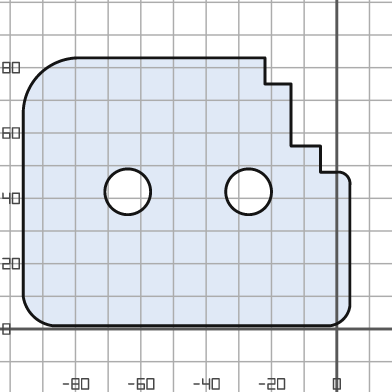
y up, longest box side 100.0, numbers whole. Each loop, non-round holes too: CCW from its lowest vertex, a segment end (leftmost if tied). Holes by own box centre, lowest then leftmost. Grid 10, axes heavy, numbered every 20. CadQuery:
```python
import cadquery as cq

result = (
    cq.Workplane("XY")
    .moveTo(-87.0, 1.0)
    .lineTo(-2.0, 1.0)
    .threePointArc((2.0, 3.0), (4.0, 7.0))
    .lineTo(4.0, 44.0)
    .threePointArc((3.0, 47.0), (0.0, 48.0))
    .lineTo(-5.0, 48.0)
    .lineTo(-5.0, 56.0)
    .lineTo(-14.0, 56.0)
    .lineTo(-14.0, 75.0)
    .lineTo(-22.0, 75.0)
    .lineTo(-22.0, 83.0)
    .lineTo(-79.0, 83.0)
    .threePointArc((-91.0, 78.0), (-96.0, 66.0))
    .lineTo(-96.0, 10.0)
    .threePointArc((-93.0, 4.0), (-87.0, 1.0))
    .close()
    .moveTo(-64.0, 42.0)
    .circle(7.0)
    .moveTo(-27.0, 42.0)
    .circle(7.0)
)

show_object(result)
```